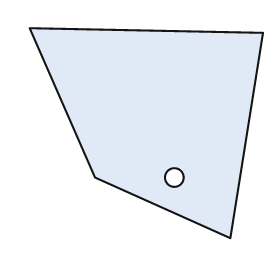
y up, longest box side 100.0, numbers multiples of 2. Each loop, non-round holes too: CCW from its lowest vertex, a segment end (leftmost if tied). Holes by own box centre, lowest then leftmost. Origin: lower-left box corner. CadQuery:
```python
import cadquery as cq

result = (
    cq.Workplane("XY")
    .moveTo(86.0, 0.0)
    .lineTo(100.0, 88.0)
    .lineTo(0.0, 90.0)
    .lineTo(28.0, 26.0)
    .close()
    .moveTo(62.0, 26.0)
    .circle(4.0)
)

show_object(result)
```